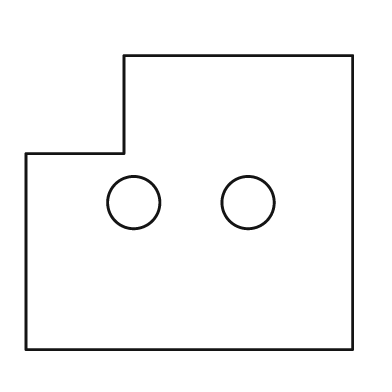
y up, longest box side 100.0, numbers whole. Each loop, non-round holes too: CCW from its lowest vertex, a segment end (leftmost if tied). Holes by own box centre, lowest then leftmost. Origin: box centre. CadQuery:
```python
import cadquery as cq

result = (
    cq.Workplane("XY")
    .moveTo(-50.0, -45.0)
    .lineTo(50.0, -45.0)
    .lineTo(50.0, 45.0)
    .lineTo(-20.0, 45.0)
    .lineTo(-20.0, 15.0)
    .lineTo(-50.0, 15.0)
    .close()
    .moveTo(-17.0, 0.0)
    .circle(8.0)
    .moveTo(18.0, 0.0)
    .circle(8.0)
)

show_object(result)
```